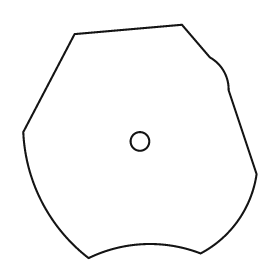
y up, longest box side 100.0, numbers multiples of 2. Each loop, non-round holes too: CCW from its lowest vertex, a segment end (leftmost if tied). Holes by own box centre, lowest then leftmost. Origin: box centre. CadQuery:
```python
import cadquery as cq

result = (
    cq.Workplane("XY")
    .moveTo(-22.0, -50.0)
    .threePointArc((2.0, -44.0), (26.0, -48.0))
    .threePointArc((42.0, -34.0), (50.0, -14.0))
    .lineTo(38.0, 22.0)
    .threePointArc((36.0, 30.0), (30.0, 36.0))
    .lineTo(18.0, 50.0)
    .lineTo(-28.0, 46.0)
    .lineTo(-50.0, 4.0)
    .threePointArc((-42.0, -26.0), (-22.0, -50.0))
    .close()
    .moveTo(0.0, 0.0)
    .circle(4.0)
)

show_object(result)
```